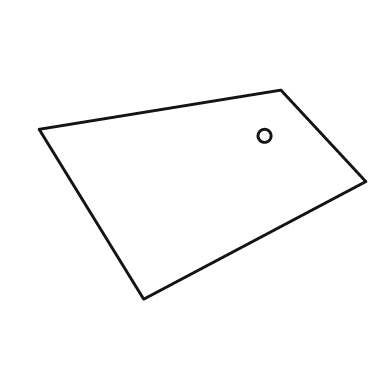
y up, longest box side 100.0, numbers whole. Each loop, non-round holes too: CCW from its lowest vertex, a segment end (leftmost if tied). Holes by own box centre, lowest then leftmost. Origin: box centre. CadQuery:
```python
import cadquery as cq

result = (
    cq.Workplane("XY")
    .moveTo(-18.0, -32.0)
    .lineTo(50.0, 4.0)
    .lineTo(24.0, 32.0)
    .lineTo(-50.0, 20.0)
    .close()
    .moveTo(19.0, 18.0)
    .circle(2.0)
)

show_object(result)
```